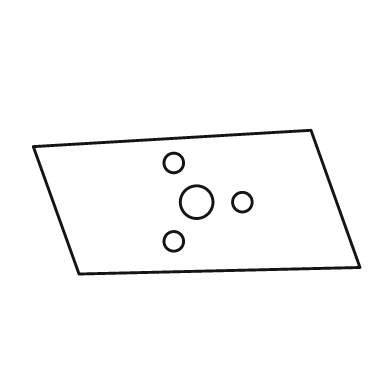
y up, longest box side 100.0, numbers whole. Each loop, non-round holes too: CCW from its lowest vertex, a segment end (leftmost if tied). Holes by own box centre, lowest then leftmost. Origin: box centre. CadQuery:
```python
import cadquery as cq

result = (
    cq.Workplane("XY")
    .moveTo(-36.0, -22.0)
    .lineTo(50.0, -20.0)
    .lineTo(35.0, 22.0)
    .lineTo(-50.0, 17.0)
    .close()
    .moveTo(-7.0, -12.0)
    .circle(3.0)
    .moveTo(0.0, 0.0)
    .circle(5.0)
    .moveTo(14.0, 0.0)
    .circle(3.0)
    .moveTo(-7.0, 12.0)
    .circle(3.0)
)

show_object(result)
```